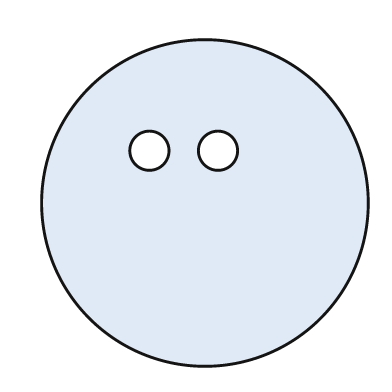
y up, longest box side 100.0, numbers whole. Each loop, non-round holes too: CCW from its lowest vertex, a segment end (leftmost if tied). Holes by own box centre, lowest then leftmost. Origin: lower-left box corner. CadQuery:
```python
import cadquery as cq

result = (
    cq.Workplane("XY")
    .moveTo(50.0, 50.0)
    .circle(50.0)
    .moveTo(33.0, 66.0)
    .circle(6.0)
    .moveTo(54.0, 66.0)
    .circle(6.0)
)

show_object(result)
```